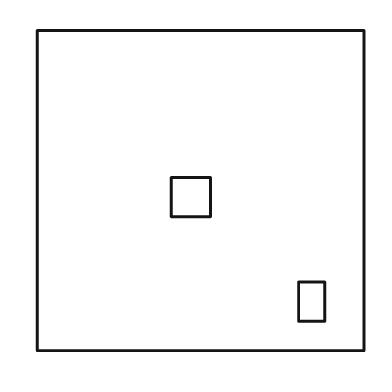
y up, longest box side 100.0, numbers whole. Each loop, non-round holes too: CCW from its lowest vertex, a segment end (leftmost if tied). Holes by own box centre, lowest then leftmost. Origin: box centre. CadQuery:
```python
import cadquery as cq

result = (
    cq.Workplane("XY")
    .moveTo(-50.0, -49.0)
    .lineTo(50.0, -49.0)
    .lineTo(50.0, 49.0)
    .lineTo(-50.0, 49.0)
    .close()
    .moveTo(30.0, -40.0)
    .lineTo(38.0, -40.0)
    .lineTo(38.0, -28.0)
    .lineTo(30.0, -28.0)
    .close()
    .moveTo(-9.0, -8.0)
    .lineTo(3.0, -8.0)
    .lineTo(3.0, 4.0)
    .lineTo(-9.0, 4.0)
    .close()
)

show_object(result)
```